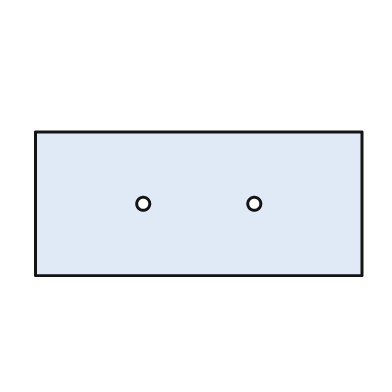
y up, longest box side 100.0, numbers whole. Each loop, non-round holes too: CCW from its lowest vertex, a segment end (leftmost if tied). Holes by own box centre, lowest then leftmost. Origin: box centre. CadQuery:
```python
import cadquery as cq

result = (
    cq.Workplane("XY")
    .moveTo(-50.0, -22.0)
    .lineTo(50.0, -22.0)
    .lineTo(50.0, 22.0)
    .lineTo(-50.0, 22.0)
    .close()
    .moveTo(-17.0, 0.0)
    .circle(2.0)
    .moveTo(17.0, 0.0)
    .circle(2.0)
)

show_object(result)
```